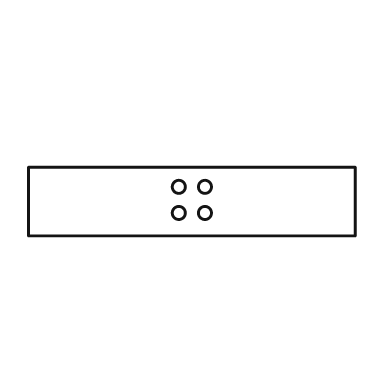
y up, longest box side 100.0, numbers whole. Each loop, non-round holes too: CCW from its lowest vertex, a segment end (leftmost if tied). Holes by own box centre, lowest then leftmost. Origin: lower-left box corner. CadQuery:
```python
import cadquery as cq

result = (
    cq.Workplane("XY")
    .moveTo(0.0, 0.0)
    .lineTo(100.0, 0.0)
    .lineTo(100.0, 21.0)
    .lineTo(0.0, 21.0)
    .close()
    .moveTo(46.0, 7.0)
    .circle(2.0)
    .moveTo(54.0, 7.0)
    .circle(2.0)
    .moveTo(46.0, 15.0)
    .circle(2.0)
    .moveTo(54.0, 15.0)
    .circle(2.0)
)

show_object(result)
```